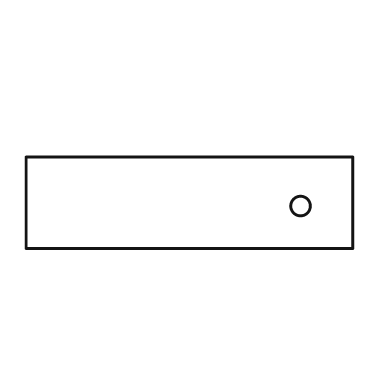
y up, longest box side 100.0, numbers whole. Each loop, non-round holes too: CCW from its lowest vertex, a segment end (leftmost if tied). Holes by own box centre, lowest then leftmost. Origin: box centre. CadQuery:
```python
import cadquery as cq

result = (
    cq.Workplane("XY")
    .moveTo(-50.0, -14.0)
    .lineTo(50.0, -14.0)
    .lineTo(50.0, 14.0)
    .lineTo(-50.0, 14.0)
    .close()
    .moveTo(34.0, -1.0)
    .circle(3.0)
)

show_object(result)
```